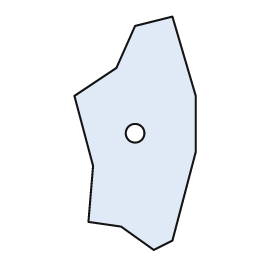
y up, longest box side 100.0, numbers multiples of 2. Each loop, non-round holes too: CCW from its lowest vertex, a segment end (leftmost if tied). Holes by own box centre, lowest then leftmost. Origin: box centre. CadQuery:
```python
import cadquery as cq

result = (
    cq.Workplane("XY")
    .moveTo(8.0, -50.0)
    .lineTo(16.0, -46.0)
    .lineTo(26.0, -8.0)
    .lineTo(26.0, 16.0)
    .lineTo(16.0, 50.0)
    .lineTo(0.0, 46.0)
    .lineTo(-8.0, 28.0)
    .lineTo(-26.0, 16.0)
    .lineTo(-18.0, -14.0)
    .lineTo(-20.0, -38.0)
    .lineTo(-6.0, -40.0)
    .close()
    .moveTo(0.0, 0.0)
    .circle(4.0)
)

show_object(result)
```